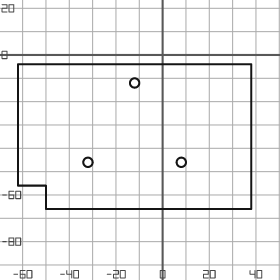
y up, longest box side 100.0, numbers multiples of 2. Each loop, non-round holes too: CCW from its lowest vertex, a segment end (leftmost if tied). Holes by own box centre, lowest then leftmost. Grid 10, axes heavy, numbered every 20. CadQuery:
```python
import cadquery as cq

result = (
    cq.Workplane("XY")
    .moveTo(-50.0, -66.0)
    .lineTo(38.0, -66.0)
    .lineTo(38.0, -4.0)
    .lineTo(-62.0, -4.0)
    .lineTo(-62.0, -56.0)
    .lineTo(-50.0, -56.0)
    .close()
    .moveTo(-32.0, -46.0)
    .circle(2.0)
    .moveTo(8.0, -46.0)
    .circle(2.0)
    .moveTo(-12.0, -12.0)
    .circle(2.0)
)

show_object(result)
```